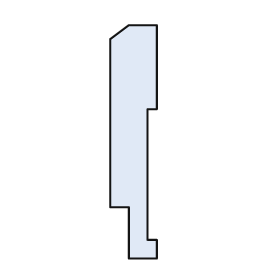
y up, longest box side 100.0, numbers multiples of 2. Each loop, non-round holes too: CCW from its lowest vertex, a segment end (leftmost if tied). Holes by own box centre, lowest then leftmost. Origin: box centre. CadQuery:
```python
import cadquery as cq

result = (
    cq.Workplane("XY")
    .moveTo(-2.0, -50.0)
    .lineTo(10.0, -50.0)
    .lineTo(10.0, -42.0)
    .lineTo(6.0, -42.0)
    .lineTo(6.0, 14.0)
    .lineTo(10.0, 14.0)
    .lineTo(10.0, 50.0)
    .lineTo(-2.0, 50.0)
    .lineTo(-10.0, 44.0)
    .lineTo(-10.0, -28.0)
    .lineTo(-2.0, -28.0)
    .close()
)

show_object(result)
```